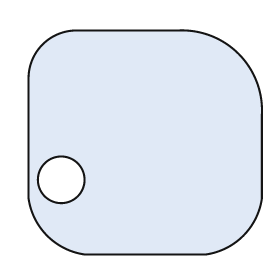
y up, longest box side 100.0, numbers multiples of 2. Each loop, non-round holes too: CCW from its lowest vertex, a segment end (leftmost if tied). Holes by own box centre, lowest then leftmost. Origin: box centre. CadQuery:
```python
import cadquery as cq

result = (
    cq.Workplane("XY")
    .moveTo(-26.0, -48.0)
    .lineTo(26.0, -48.0)
    .threePointArc((42.0, -40.0), (50.0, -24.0))
    .lineTo(50.0, 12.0)
    .threePointArc((40.0, 38.0), (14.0, 48.0))
    .lineTo(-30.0, 48.0)
    .threePointArc((-44.0, 42.0), (-50.0, 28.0))
    .lineTo(-50.0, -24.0)
    .threePointArc((-42.0, -40.0), (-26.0, -48.0))
    .close()
    .moveTo(-36.0, -16.0)
    .circle(10.0)
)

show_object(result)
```